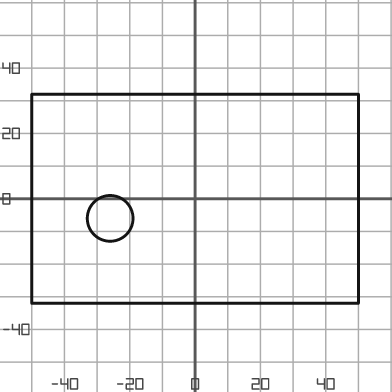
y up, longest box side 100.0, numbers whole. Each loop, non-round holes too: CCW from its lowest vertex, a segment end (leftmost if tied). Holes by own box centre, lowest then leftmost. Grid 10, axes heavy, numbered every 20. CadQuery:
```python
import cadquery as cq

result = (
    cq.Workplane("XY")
    .moveTo(-50.0, -32.0)
    .lineTo(50.0, -32.0)
    .lineTo(50.0, 32.0)
    .lineTo(-50.0, 32.0)
    .close()
    .moveTo(-26.0, -6.0)
    .circle(7.0)
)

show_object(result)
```